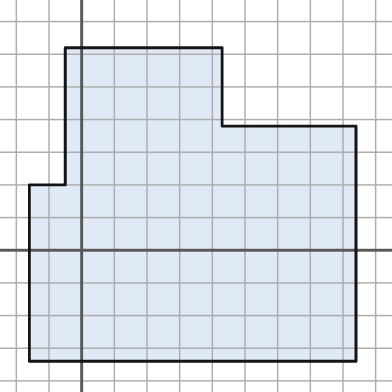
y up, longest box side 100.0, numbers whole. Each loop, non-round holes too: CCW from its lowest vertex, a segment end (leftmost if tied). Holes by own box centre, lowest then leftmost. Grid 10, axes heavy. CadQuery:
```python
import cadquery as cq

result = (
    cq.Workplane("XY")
    .moveTo(-16.0, -34.0)
    .lineTo(84.0, -34.0)
    .lineTo(84.0, 38.0)
    .lineTo(43.0, 38.0)
    .lineTo(43.0, 62.0)
    .lineTo(-5.0, 62.0)
    .lineTo(-5.0, 20.0)
    .lineTo(-16.0, 20.0)
    .close()
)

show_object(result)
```